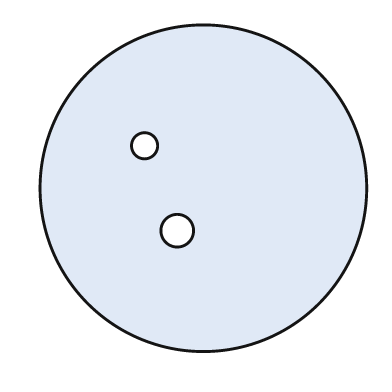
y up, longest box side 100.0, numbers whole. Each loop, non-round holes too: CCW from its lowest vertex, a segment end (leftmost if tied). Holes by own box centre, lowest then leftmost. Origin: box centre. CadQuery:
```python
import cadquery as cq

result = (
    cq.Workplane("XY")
    .moveTo(0.0, 0.0)
    .circle(50.0)
    .moveTo(-8.0, -13.0)
    .circle(5.0)
    .moveTo(-18.0, 13.0)
    .circle(4.0)
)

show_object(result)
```